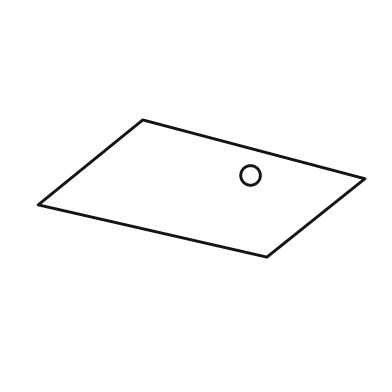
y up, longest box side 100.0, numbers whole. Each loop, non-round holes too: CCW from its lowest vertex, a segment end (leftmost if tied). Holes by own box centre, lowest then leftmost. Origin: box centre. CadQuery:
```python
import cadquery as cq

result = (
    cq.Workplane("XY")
    .moveTo(20.0, -21.0)
    .lineTo(50.0, 3.0)
    .lineTo(-18.0, 21.0)
    .lineTo(-50.0, -5.0)
    .close()
    .moveTo(15.0, 4.0)
    .circle(3.0)
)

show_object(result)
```